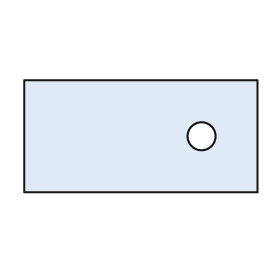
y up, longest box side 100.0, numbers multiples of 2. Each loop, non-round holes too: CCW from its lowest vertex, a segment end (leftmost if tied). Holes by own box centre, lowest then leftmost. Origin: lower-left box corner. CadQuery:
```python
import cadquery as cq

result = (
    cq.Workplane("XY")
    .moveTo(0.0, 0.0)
    .lineTo(100.0, 0.0)
    .lineTo(100.0, 48.0)
    .lineTo(0.0, 48.0)
    .close()
    .moveTo(76.0, 24.0)
    .circle(6.0)
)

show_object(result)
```